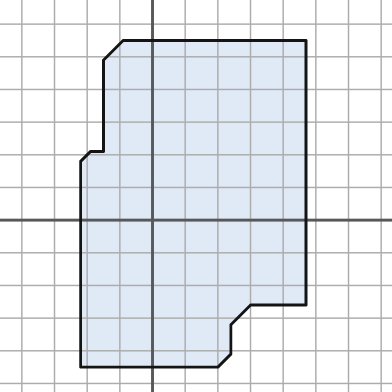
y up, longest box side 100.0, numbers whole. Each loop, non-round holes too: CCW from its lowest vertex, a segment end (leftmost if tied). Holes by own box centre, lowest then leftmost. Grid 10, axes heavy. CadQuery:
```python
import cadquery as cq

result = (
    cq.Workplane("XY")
    .moveTo(-22.0, -45.0)
    .lineTo(20.0, -45.0)
    .lineTo(24.0, -41.0)
    .lineTo(24.0, -32.0)
    .lineTo(30.0, -26.0)
    .lineTo(47.0, -26.0)
    .lineTo(47.0, 55.0)
    .lineTo(-9.0, 55.0)
    .lineTo(-15.0, 49.0)
    .lineTo(-15.0, 21.0)
    .lineTo(-19.0, 21.0)
    .lineTo(-22.0, 18.0)
    .close()
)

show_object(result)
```